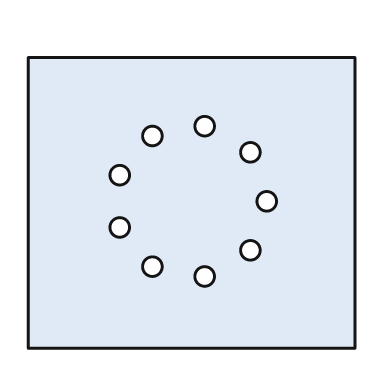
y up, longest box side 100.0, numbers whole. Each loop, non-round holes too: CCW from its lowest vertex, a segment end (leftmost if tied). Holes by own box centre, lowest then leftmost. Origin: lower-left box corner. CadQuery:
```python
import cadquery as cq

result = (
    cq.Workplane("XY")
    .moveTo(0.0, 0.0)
    .lineTo(100.0, 0.0)
    .lineTo(100.0, 89.0)
    .lineTo(0.0, 89.0)
    .close()
    .moveTo(54.0, 22.0)
    .circle(3.0)
    .moveTo(38.0, 25.0)
    .circle(3.0)
    .moveTo(68.0, 30.0)
    .circle(3.0)
    .moveTo(28.0, 37.0)
    .circle(3.0)
    .moveTo(73.0, 45.0)
    .circle(3.0)
    .moveTo(28.0, 53.0)
    .circle(3.0)
    .moveTo(68.0, 60.0)
    .circle(3.0)
    .moveTo(38.0, 65.0)
    .circle(3.0)
    .moveTo(54.0, 68.0)
    .circle(3.0)
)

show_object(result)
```